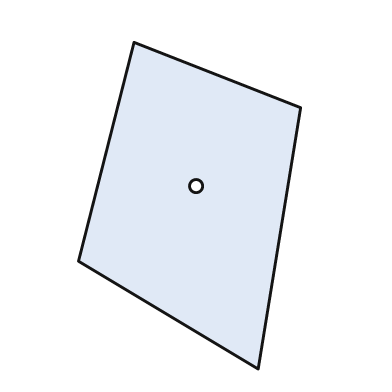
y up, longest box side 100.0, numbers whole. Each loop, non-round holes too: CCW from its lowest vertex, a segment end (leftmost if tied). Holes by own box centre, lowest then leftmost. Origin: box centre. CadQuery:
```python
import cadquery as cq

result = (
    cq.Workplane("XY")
    .moveTo(21.0, -50.0)
    .lineTo(34.0, 30.0)
    .lineTo(-17.0, 50.0)
    .lineTo(-34.0, -17.0)
    .close()
    .moveTo(2.0, 6.0)
    .circle(2.0)
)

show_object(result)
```